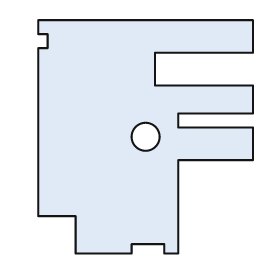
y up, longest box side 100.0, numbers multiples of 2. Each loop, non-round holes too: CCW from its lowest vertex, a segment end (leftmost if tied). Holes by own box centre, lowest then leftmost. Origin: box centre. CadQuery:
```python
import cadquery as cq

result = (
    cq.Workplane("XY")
    .moveTo(-30.0, -50.0)
    .lineTo(-6.0, -50.0)
    .lineTo(-6.0, -46.0)
    .lineTo(8.0, -46.0)
    .lineTo(8.0, -50.0)
    .lineTo(14.0, -50.0)
    .lineTo(14.0, -10.0)
    .lineTo(46.0, -10.0)
    .lineTo(46.0, 4.0)
    .lineTo(14.0, 4.0)
    .lineTo(14.0, 10.0)
    .lineTo(46.0, 10.0)
    .lineTo(46.0, 22.0)
    .lineTo(4.0, 22.0)
    .lineTo(4.0, 36.0)
    .lineTo(46.0, 36.0)
    .lineTo(46.0, 50.0)
    .lineTo(-46.0, 50.0)
    .lineTo(-46.0, 44.0)
    .lineTo(-42.0, 44.0)
    .lineTo(-42.0, 38.0)
    .lineTo(-46.0, 38.0)
    .lineTo(-46.0, -34.0)
    .lineTo(-30.0, -34.0)
    .close()
    .moveTo(0.0, 0.0)
    .circle(6.0)
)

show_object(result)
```